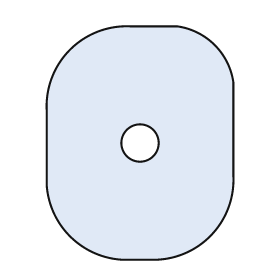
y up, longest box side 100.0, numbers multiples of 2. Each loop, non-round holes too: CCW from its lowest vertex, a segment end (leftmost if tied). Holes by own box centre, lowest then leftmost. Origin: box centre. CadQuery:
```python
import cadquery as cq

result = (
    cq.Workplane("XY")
    .moveTo(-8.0, -50.0)
    .lineTo(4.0, -50.0)
    .threePointArc((30.0, -40.0), (40.0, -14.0))
    .lineTo(40.0, 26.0)
    .threePointArc((32.0, 42.0), (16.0, 50.0))
    .lineTo(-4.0, 50.0)
    .threePointArc((-30.0, 40.0), (-40.0, 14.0))
    .lineTo(-40.0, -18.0)
    .threePointArc((-30.0, -40.0), (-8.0, -50.0))
    .close()
    .moveTo(0.0, 0.0)
    .circle(8.0)
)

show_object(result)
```